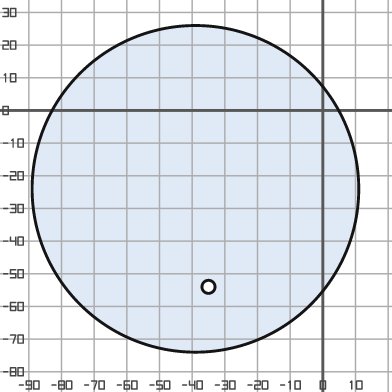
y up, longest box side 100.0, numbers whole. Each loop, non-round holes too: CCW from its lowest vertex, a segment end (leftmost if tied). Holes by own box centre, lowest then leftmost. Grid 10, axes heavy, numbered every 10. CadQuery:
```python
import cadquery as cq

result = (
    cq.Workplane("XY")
    .moveTo(-39.0, -24.0)
    .circle(50.0)
    .moveTo(-35.0, -54.0)
    .circle(2.0)
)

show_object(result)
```